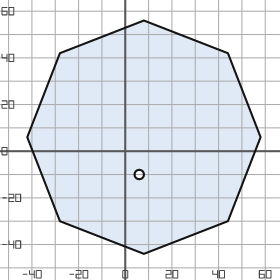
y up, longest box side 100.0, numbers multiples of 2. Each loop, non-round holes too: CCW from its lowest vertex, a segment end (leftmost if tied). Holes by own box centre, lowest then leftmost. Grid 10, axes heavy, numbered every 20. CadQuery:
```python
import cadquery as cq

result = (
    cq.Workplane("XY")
    .moveTo(8.0, -44.0)
    .lineTo(44.0, -30.0)
    .lineTo(58.0, 6.0)
    .lineTo(44.0, 42.0)
    .lineTo(8.0, 56.0)
    .lineTo(-28.0, 42.0)
    .lineTo(-42.0, 6.0)
    .lineTo(-28.0, -30.0)
    .close()
    .moveTo(6.0, -10.0)
    .circle(2.0)
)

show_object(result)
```